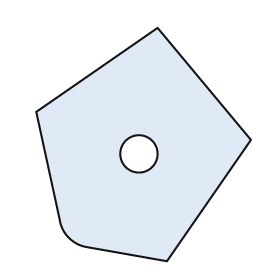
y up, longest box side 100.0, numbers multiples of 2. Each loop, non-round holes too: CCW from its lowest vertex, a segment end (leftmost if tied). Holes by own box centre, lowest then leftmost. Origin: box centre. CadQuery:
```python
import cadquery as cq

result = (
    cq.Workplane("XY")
    .moveTo(10.0, -50.0)
    .lineTo(46.0, 2.0)
    .lineTo(6.0, 50.0)
    .lineTo(-46.0, 14.0)
    .lineTo(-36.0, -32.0)
    .threePointArc((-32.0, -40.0), (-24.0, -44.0))
    .close()
    .moveTo(-2.0, -4.0)
    .circle(8.0)
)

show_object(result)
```